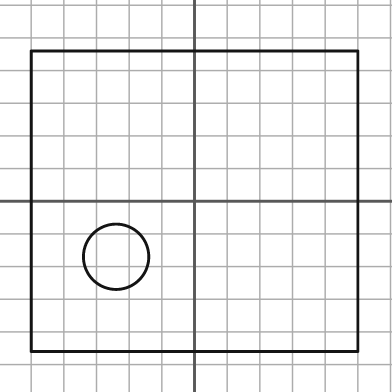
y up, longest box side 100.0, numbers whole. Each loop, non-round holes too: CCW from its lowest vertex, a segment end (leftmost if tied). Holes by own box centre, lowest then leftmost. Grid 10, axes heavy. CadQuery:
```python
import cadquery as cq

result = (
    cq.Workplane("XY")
    .moveTo(-50.0, -46.0)
    .lineTo(50.0, -46.0)
    .lineTo(50.0, 46.0)
    .lineTo(-50.0, 46.0)
    .close()
    .moveTo(-24.0, -17.0)
    .circle(10.0)
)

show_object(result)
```